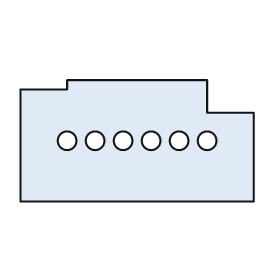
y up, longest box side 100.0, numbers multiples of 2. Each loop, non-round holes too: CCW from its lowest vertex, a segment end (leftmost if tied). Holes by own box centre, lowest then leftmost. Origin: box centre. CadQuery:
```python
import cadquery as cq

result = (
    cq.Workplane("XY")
    .moveTo(-50.0, -26.0)
    .lineTo(50.0, -26.0)
    .lineTo(50.0, 12.0)
    .lineTo(30.0, 12.0)
    .lineTo(30.0, 26.0)
    .lineTo(-30.0, 26.0)
    .lineTo(-30.0, 22.0)
    .lineTo(-50.0, 22.0)
    .close()
    .moveTo(-30.0, 0.0)
    .circle(4.0)
    .moveTo(-18.0, 0.0)
    .circle(4.0)
    .moveTo(-6.0, 0.0)
    .circle(4.0)
    .moveTo(6.0, 0.0)
    .circle(4.0)
    .moveTo(18.0, 0.0)
    .circle(4.0)
    .moveTo(30.0, 0.0)
    .circle(4.0)
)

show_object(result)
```